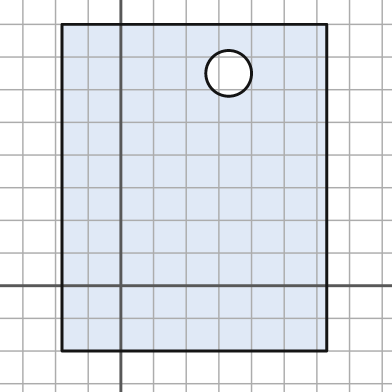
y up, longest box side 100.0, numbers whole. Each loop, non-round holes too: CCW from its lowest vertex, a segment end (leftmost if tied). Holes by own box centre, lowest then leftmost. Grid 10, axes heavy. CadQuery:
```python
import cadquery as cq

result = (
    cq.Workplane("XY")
    .moveTo(-18.0, -20.0)
    .lineTo(63.0, -20.0)
    .lineTo(63.0, 80.0)
    .lineTo(-18.0, 80.0)
    .close()
    .moveTo(33.0, 65.0)
    .circle(7.0)
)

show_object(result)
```